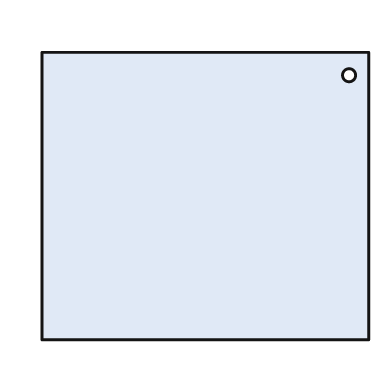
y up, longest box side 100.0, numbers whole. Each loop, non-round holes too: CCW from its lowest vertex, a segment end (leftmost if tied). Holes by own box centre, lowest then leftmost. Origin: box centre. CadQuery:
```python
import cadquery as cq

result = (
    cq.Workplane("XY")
    .moveTo(-50.0, -44.0)
    .lineTo(50.0, -44.0)
    .lineTo(50.0, 44.0)
    .lineTo(-50.0, 44.0)
    .close()
    .moveTo(44.0, 37.0)
    .circle(2.0)
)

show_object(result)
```